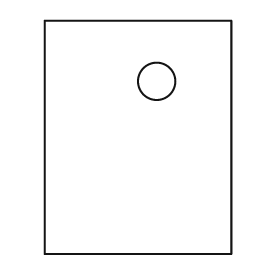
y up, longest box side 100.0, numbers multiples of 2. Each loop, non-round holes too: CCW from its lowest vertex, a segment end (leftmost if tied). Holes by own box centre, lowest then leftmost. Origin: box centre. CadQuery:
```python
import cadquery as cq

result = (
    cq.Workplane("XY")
    .moveTo(-40.0, -50.0)
    .lineTo(40.0, -50.0)
    .lineTo(40.0, 50.0)
    .lineTo(-40.0, 50.0)
    .close()
    .moveTo(8.0, 24.0)
    .circle(8.0)
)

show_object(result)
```